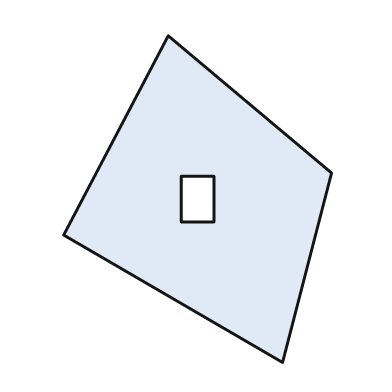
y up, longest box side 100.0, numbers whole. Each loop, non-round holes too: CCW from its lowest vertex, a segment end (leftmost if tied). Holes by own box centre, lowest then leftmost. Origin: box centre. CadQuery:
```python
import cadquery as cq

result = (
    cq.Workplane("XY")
    .moveTo(26.0, -50.0)
    .lineTo(41.0, 8.0)
    .lineTo(-9.0, 50.0)
    .lineTo(-41.0, -11.0)
    .close()
    .moveTo(-5.0, -7.0)
    .lineTo(5.0, -7.0)
    .lineTo(5.0, 7.0)
    .lineTo(-5.0, 7.0)
    .close()
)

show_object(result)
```